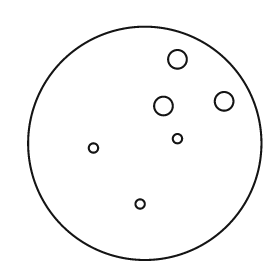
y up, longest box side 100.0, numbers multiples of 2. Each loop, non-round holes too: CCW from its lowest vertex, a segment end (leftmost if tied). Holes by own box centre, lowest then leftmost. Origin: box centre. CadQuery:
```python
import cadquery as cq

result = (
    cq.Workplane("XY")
    .moveTo(0.0, 0.0)
    .circle(50.0)
    .moveTo(-2.0, -26.0)
    .circle(2.0)
    .moveTo(-22.0, -2.0)
    .circle(2.0)
    .moveTo(14.0, 2.0)
    .circle(2.0)
    .moveTo(8.0, 16.0)
    .circle(4.0)
    .moveTo(34.0, 18.0)
    .circle(4.0)
    .moveTo(14.0, 36.0)
    .circle(4.0)
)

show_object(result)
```